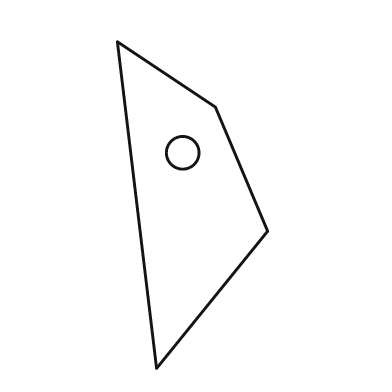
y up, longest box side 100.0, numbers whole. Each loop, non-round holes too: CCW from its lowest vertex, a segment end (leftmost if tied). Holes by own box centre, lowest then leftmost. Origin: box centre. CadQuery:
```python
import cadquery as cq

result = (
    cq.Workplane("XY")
    .moveTo(-11.0, -50.0)
    .lineTo(23.0, -8.0)
    .lineTo(7.0, 30.0)
    .lineTo(-23.0, 50.0)
    .close()
    .moveTo(-3.0, 16.0)
    .circle(5.0)
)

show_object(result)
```